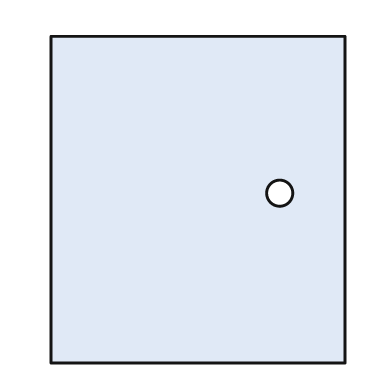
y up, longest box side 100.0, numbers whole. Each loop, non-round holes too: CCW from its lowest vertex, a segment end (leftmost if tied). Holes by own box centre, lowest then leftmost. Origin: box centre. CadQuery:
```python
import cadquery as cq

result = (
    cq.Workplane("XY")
    .moveTo(-45.0, -50.0)
    .lineTo(45.0, -50.0)
    .lineTo(45.0, 50.0)
    .lineTo(-45.0, 50.0)
    .close()
    .moveTo(25.0, 2.0)
    .circle(4.0)
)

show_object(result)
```